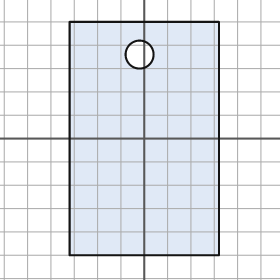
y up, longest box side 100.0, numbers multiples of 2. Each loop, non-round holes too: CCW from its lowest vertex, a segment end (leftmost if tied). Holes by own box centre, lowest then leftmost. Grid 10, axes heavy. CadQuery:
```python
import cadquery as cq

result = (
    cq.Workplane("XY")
    .moveTo(-32.0, -50.0)
    .lineTo(32.0, -50.0)
    .lineTo(32.0, 50.0)
    .lineTo(-32.0, 50.0)
    .close()
    .moveTo(-2.0, 36.0)
    .circle(6.0)
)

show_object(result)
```